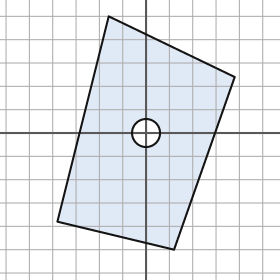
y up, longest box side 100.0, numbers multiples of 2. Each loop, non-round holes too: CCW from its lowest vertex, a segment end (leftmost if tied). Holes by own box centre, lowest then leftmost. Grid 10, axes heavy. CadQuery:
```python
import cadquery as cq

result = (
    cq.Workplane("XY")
    .moveTo(12.0, -50.0)
    .lineTo(38.0, 24.0)
    .lineTo(-16.0, 50.0)
    .lineTo(-38.0, -38.0)
    .close()
    .moveTo(0.0, 0.0)
    .circle(6.0)
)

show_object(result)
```